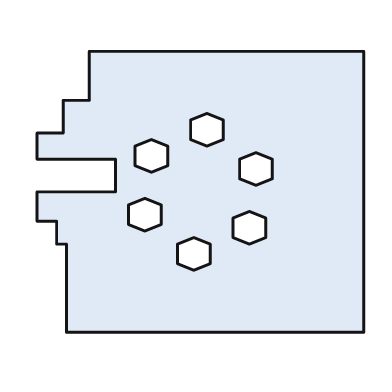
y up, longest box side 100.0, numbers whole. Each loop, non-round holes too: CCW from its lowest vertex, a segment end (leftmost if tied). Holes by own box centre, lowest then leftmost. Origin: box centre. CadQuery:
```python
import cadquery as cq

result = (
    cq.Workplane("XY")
    .moveTo(-41.0, -43.0)
    .lineTo(50.0, -43.0)
    .lineTo(50.0, 43.0)
    .lineTo(-34.0, 43.0)
    .lineTo(-34.0, 28.0)
    .lineTo(-42.0, 28.0)
    .lineTo(-42.0, 18.0)
    .lineTo(-50.0, 18.0)
    .lineTo(-50.0, 10.0)
    .lineTo(-26.0, 10.0)
    .lineTo(-26.0, 0.0)
    .lineTo(-50.0, 0.0)
    .lineTo(-50.0, -9.0)
    .lineTo(-44.0, -9.0)
    .lineTo(-44.0, -16.0)
    .lineTo(-41.0, -16.0)
    .close()
    .moveTo(-2.0, -24.0)
    .lineTo(3.0, -22.0)
    .lineTo(3.0, -16.0)
    .lineTo(-2.0, -14.0)
    .lineTo(-7.0, -16.0)
    .lineTo(-7.0, -22.0)
    .close()
    .moveTo(15.0, -16.0)
    .lineTo(20.0, -14.0)
    .lineTo(20.0, -8.0)
    .lineTo(15.0, -6.0)
    .lineTo(10.0, -8.0)
    .lineTo(10.0, -14.0)
    .close()
    .moveTo(-17.0, -12.0)
    .lineTo(-12.0, -10.0)
    .lineTo(-12.0, -4.0)
    .lineTo(-17.0, -2.0)
    .lineTo(-22.0, -4.0)
    .lineTo(-22.0, -10.0)
    .close()
    .moveTo(17.0, 2.0)
    .lineTo(22.0, 4.0)
    .lineTo(22.0, 10.0)
    .lineTo(17.0, 12.0)
    .lineTo(12.0, 10.0)
    .lineTo(12.0, 4.0)
    .close()
    .moveTo(-15.0, 6.0)
    .lineTo(-10.0, 8.0)
    .lineTo(-10.0, 14.0)
    .lineTo(-15.0, 16.0)
    .lineTo(-20.0, 14.0)
    .lineTo(-20.0, 8.0)
    .close()
    .moveTo(2.0, 14.0)
    .lineTo(7.0, 16.0)
    .lineTo(7.0, 22.0)
    .lineTo(2.0, 24.0)
    .lineTo(-3.0, 22.0)
    .lineTo(-3.0, 16.0)
    .close()
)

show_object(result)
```